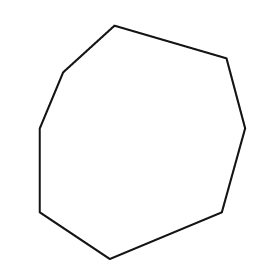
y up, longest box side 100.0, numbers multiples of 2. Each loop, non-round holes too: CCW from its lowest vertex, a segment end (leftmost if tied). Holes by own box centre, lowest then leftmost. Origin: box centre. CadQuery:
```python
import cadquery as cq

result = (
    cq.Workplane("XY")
    .moveTo(-14.0, -50.0)
    .lineTo(34.0, -30.0)
    .lineTo(44.0, 6.0)
    .lineTo(36.0, 36.0)
    .lineTo(-12.0, 50.0)
    .lineTo(-34.0, 30.0)
    .lineTo(-44.0, 6.0)
    .lineTo(-44.0, -30.0)
    .close()
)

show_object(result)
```